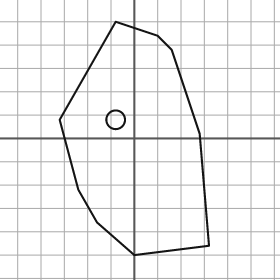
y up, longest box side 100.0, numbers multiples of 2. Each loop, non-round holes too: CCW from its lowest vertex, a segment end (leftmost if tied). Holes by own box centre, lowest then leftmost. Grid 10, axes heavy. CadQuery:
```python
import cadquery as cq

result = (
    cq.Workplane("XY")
    .moveTo(0.0, -50.0)
    .lineTo(32.0, -46.0)
    .lineTo(28.0, 2.0)
    .lineTo(16.0, 38.0)
    .lineTo(10.0, 44.0)
    .lineTo(-8.0, 50.0)
    .lineTo(-32.0, 8.0)
    .lineTo(-24.0, -22.0)
    .lineTo(-16.0, -36.0)
    .close()
    .moveTo(-8.0, 8.0)
    .circle(4.0)
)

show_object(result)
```